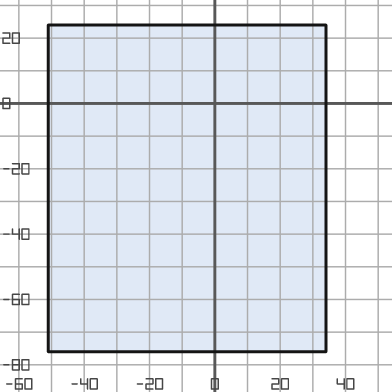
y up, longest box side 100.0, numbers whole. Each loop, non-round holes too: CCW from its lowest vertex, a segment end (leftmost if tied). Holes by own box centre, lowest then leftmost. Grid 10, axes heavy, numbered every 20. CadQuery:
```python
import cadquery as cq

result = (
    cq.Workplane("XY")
    .moveTo(-51.0, -76.0)
    .lineTo(34.0, -76.0)
    .lineTo(34.0, 24.0)
    .lineTo(-51.0, 24.0)
    .close()
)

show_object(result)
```